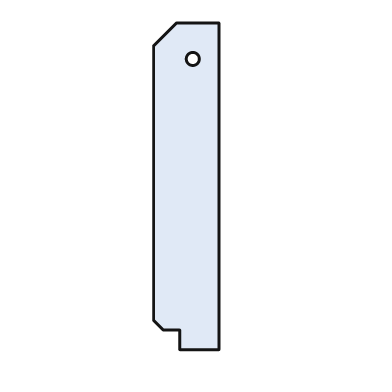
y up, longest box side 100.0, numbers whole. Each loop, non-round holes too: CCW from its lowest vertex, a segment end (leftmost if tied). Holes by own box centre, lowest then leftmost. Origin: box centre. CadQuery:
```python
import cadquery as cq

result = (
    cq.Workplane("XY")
    .moveTo(-2.0, -50.0)
    .lineTo(10.0, -50.0)
    .lineTo(10.0, 50.0)
    .lineTo(-3.0, 50.0)
    .lineTo(-10.0, 43.0)
    .lineTo(-10.0, -41.0)
    .lineTo(-7.0, -44.0)
    .lineTo(-2.0, -44.0)
    .close()
    .moveTo(2.0, 39.0)
    .circle(2.0)
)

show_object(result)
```